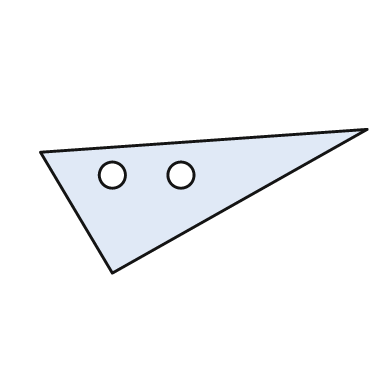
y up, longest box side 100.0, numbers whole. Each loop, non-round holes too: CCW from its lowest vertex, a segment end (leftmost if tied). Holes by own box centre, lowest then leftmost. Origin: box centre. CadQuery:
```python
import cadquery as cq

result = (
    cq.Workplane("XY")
    .moveTo(-28.0, -22.0)
    .lineTo(50.0, 22.0)
    .lineTo(-50.0, 15.0)
    .close()
    .moveTo(-28.0, 8.0)
    .circle(4.0)
    .moveTo(-7.0, 8.0)
    .circle(4.0)
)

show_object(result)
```